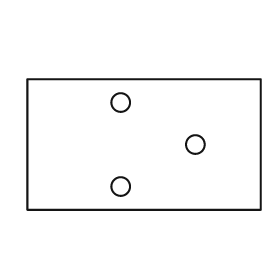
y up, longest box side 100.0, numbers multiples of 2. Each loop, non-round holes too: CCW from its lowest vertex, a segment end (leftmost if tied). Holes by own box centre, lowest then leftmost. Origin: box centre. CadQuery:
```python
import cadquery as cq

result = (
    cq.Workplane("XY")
    .moveTo(-50.0, -28.0)
    .lineTo(50.0, -28.0)
    .lineTo(50.0, 28.0)
    .lineTo(-50.0, 28.0)
    .close()
    .moveTo(-10.0, -18.0)
    .circle(4.0)
    .moveTo(22.0, 0.0)
    .circle(4.0)
    .moveTo(-10.0, 18.0)
    .circle(4.0)
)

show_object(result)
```